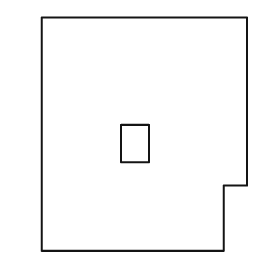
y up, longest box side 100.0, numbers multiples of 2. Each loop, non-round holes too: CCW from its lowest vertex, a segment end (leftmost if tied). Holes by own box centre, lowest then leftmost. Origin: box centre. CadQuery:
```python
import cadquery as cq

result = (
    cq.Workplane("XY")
    .moveTo(-44.0, -50.0)
    .lineTo(34.0, -50.0)
    .lineTo(34.0, -22.0)
    .lineTo(44.0, -22.0)
    .lineTo(44.0, 50.0)
    .lineTo(-44.0, 50.0)
    .close()
    .moveTo(-10.0, -12.0)
    .lineTo(2.0, -12.0)
    .lineTo(2.0, 4.0)
    .lineTo(-10.0, 4.0)
    .close()
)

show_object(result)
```